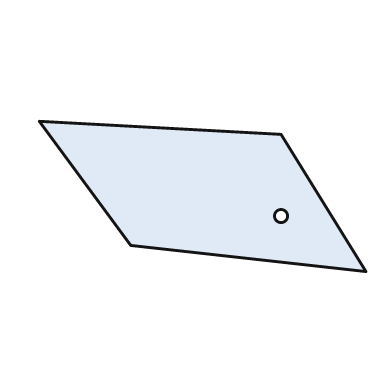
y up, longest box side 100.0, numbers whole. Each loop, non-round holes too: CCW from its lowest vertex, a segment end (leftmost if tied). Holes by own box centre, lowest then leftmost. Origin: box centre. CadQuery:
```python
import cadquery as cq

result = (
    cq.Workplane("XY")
    .moveTo(50.0, -23.0)
    .lineTo(24.0, 19.0)
    .lineTo(-50.0, 23.0)
    .lineTo(-22.0, -15.0)
    .close()
    .moveTo(24.0, -6.0)
    .circle(2.0)
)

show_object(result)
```